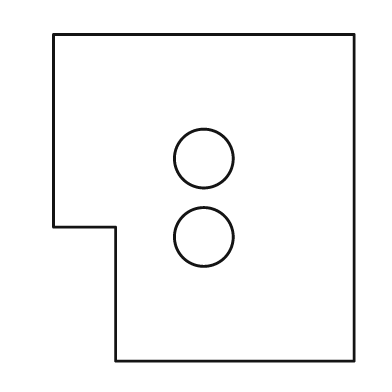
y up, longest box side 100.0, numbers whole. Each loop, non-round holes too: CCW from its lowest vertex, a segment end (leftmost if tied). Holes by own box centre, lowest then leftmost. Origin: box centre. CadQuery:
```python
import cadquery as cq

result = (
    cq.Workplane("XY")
    .moveTo(-27.0, -50.0)
    .lineTo(46.0, -50.0)
    .lineTo(46.0, 50.0)
    .lineTo(-46.0, 50.0)
    .lineTo(-46.0, -9.0)
    .lineTo(-27.0, -9.0)
    .close()
    .moveTo(0.0, -12.0)
    .circle(9.0)
    .moveTo(0.0, 12.0)
    .circle(9.0)
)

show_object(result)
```